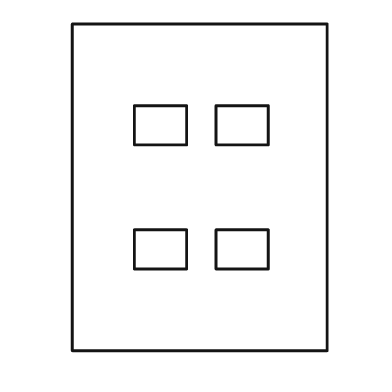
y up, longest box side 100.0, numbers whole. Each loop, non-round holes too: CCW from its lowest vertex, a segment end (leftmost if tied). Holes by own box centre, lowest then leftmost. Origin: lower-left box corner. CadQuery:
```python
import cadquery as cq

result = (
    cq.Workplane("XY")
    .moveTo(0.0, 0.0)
    .lineTo(78.0, 0.0)
    .lineTo(78.0, 100.0)
    .lineTo(0.0, 100.0)
    .close()
    .moveTo(19.0, 25.0)
    .lineTo(35.0, 25.0)
    .lineTo(35.0, 37.0)
    .lineTo(19.0, 37.0)
    .close()
    .moveTo(44.0, 25.0)
    .lineTo(60.0, 25.0)
    .lineTo(60.0, 37.0)
    .lineTo(44.0, 37.0)
    .close()
    .moveTo(19.0, 63.0)
    .lineTo(35.0, 63.0)
    .lineTo(35.0, 75.0)
    .lineTo(19.0, 75.0)
    .close()
    .moveTo(44.0, 63.0)
    .lineTo(60.0, 63.0)
    .lineTo(60.0, 75.0)
    .lineTo(44.0, 75.0)
    .close()
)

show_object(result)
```